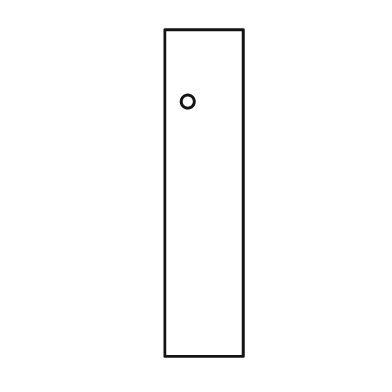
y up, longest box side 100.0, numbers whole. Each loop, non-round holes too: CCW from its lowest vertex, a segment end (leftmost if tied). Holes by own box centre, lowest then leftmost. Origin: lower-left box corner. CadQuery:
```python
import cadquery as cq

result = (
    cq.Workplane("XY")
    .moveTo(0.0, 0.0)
    .lineTo(24.0, 0.0)
    .lineTo(24.0, 100.0)
    .lineTo(0.0, 100.0)
    .close()
    .moveTo(7.0, 78.0)
    .circle(2.0)
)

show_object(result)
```